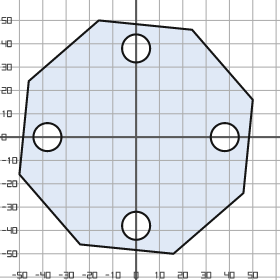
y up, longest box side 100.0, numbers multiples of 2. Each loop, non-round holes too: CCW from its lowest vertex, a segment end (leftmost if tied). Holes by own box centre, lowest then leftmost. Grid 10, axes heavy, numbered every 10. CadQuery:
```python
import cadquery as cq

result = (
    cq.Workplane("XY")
    .moveTo(16.0, -50.0)
    .lineTo(46.0, -24.0)
    .lineTo(50.0, 16.0)
    .lineTo(24.0, 46.0)
    .lineTo(-16.0, 50.0)
    .lineTo(-46.0, 24.0)
    .lineTo(-50.0, -16.0)
    .lineTo(-24.0, -46.0)
    .close()
    .moveTo(0.0, -38.0)
    .circle(6.0)
    .moveTo(-38.0, 0.0)
    .circle(6.0)
    .moveTo(38.0, 0.0)
    .circle(6.0)
    .moveTo(0.0, 38.0)
    .circle(6.0)
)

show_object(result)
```